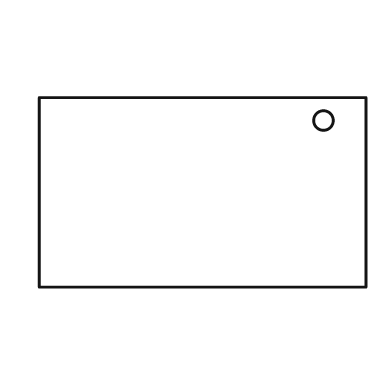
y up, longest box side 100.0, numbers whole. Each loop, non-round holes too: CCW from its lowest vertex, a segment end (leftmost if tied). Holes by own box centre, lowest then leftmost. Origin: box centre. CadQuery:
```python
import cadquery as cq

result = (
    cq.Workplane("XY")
    .moveTo(-50.0, -29.0)
    .lineTo(50.0, -29.0)
    .lineTo(50.0, 29.0)
    .lineTo(-50.0, 29.0)
    .close()
    .moveTo(37.0, 22.0)
    .circle(3.0)
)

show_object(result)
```